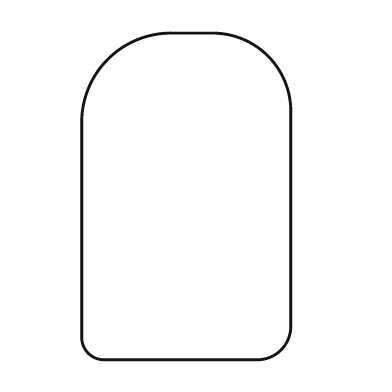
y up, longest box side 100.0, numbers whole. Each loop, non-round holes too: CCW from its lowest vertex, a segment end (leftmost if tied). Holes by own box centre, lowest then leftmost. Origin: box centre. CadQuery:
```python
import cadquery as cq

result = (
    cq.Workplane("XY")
    .moveTo(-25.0, -50.0)
    .lineTo(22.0, -50.0)
    .threePointArc((29.0, -47.0), (32.0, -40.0))
    .lineTo(32.0, 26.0)
    .threePointArc((25.0, 43.0), (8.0, 50.0))
    .lineTo(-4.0, 50.0)
    .threePointArc((-24.0, 42.0), (-32.0, 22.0))
    .lineTo(-32.0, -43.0)
    .threePointArc((-30.0, -48.0), (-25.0, -50.0))
    .close()
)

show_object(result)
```